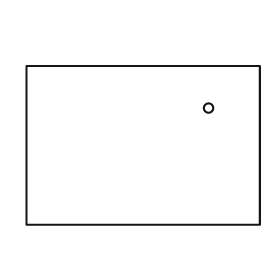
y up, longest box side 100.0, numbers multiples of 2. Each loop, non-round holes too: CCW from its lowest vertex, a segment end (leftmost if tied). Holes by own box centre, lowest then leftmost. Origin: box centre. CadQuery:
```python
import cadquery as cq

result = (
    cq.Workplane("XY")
    .moveTo(-50.0, -34.0)
    .lineTo(50.0, -34.0)
    .lineTo(50.0, 34.0)
    .lineTo(-50.0, 34.0)
    .close()
    .moveTo(28.0, 16.0)
    .circle(2.0)
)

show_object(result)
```